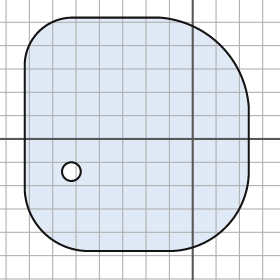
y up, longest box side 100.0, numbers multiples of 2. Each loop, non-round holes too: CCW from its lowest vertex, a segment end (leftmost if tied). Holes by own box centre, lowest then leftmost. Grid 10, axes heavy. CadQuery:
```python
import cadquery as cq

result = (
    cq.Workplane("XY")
    .moveTo(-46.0, -48.0)
    .lineTo(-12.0, -48.0)
    .threePointArc((14.0, -38.0), (24.0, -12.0))
    .lineTo(24.0, 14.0)
    .threePointArc((12.0, 40.0), (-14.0, 52.0))
    .lineTo(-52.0, 52.0)
    .threePointArc((-66.0, 46.0), (-72.0, 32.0))
    .lineTo(-72.0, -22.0)
    .threePointArc((-64.0, -40.0), (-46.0, -48.0))
    .close()
    .moveTo(-52.0, -14.0)
    .circle(4.0)
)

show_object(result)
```